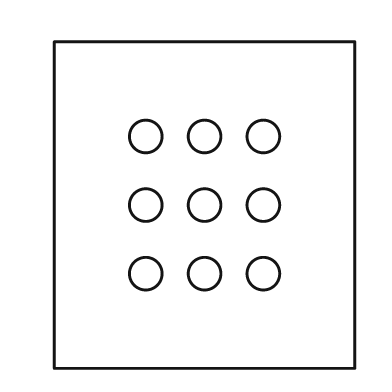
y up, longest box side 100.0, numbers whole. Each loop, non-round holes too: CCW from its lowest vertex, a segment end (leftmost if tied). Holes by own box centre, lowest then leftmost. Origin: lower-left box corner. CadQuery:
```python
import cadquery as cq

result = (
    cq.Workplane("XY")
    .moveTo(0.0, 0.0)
    .lineTo(92.0, 0.0)
    .lineTo(92.0, 100.0)
    .lineTo(0.0, 100.0)
    .close()
    .moveTo(28.0, 29.0)
    .circle(5.0)
    .moveTo(46.0, 29.0)
    .circle(5.0)
    .moveTo(64.0, 29.0)
    .circle(5.0)
    .moveTo(28.0, 50.0)
    .circle(5.0)
    .moveTo(46.0, 50.0)
    .circle(5.0)
    .moveTo(64.0, 50.0)
    .circle(5.0)
    .moveTo(28.0, 71.0)
    .circle(5.0)
    .moveTo(46.0, 71.0)
    .circle(5.0)
    .moveTo(64.0, 71.0)
    .circle(5.0)
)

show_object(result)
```